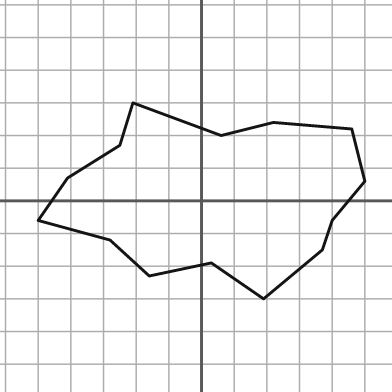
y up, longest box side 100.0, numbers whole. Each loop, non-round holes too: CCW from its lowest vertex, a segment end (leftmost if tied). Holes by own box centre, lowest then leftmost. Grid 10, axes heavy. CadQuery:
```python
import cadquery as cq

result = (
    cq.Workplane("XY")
    .moveTo(19.0, -30.0)
    .lineTo(37.0, -15.0)
    .lineTo(40.0, -6.0)
    .lineTo(50.0, 6.0)
    .lineTo(46.0, 22.0)
    .lineTo(22.0, 24.0)
    .lineTo(6.0, 20.0)
    .lineTo(-21.0, 30.0)
    .lineTo(-25.0, 17.0)
    .lineTo(-41.0, 7.0)
    .lineTo(-50.0, -6.0)
    .lineTo(-28.0, -12.0)
    .lineTo(-16.0, -23.0)
    .lineTo(3.0, -19.0)
    .close()
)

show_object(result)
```